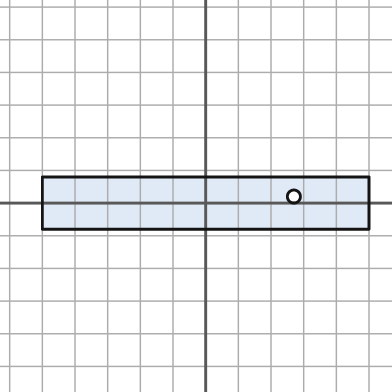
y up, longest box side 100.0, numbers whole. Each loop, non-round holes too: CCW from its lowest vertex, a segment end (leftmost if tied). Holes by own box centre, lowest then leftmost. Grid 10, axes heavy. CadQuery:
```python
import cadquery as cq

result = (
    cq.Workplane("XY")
    .moveTo(-50.0, -8.0)
    .lineTo(50.0, -8.0)
    .lineTo(50.0, 8.0)
    .lineTo(-50.0, 8.0)
    .close()
    .moveTo(27.0, 2.0)
    .circle(2.0)
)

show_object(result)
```